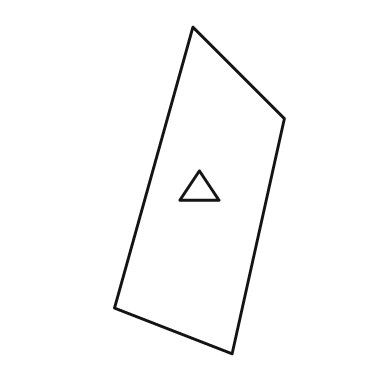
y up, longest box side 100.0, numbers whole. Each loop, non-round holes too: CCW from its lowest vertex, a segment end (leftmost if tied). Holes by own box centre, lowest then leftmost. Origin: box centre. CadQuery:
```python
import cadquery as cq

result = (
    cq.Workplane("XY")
    .moveTo(10.0, -50.0)
    .lineTo(26.0, 22.0)
    .lineTo(-2.0, 50.0)
    .lineTo(-26.0, -36.0)
    .close()
    .moveTo(-6.0, -3.0)
    .lineTo(6.0, -3.0)
    .lineTo(0.0, 6.0)
    .close()
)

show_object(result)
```